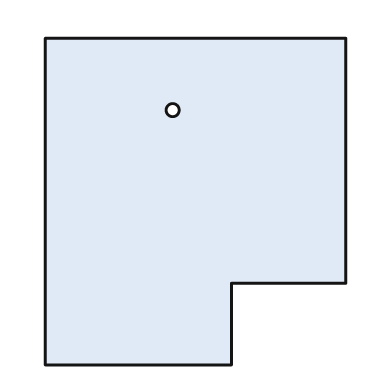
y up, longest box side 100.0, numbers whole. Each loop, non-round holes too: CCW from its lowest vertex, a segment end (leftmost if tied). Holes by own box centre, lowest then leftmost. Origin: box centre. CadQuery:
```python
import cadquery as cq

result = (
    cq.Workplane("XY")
    .moveTo(-46.0, -50.0)
    .lineTo(11.0, -50.0)
    .lineTo(11.0, -25.0)
    .lineTo(46.0, -25.0)
    .lineTo(46.0, 50.0)
    .lineTo(-46.0, 50.0)
    .close()
    .moveTo(-7.0, 28.0)
    .circle(2.0)
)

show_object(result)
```